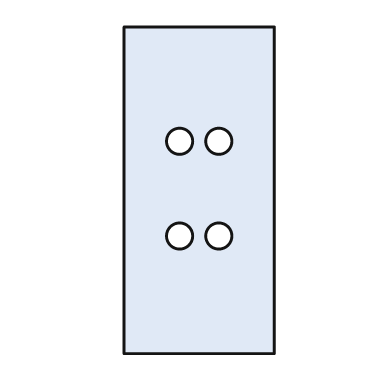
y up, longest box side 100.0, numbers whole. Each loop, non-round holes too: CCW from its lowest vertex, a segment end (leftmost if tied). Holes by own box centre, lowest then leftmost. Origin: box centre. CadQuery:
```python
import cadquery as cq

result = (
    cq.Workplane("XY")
    .moveTo(-23.0, -50.0)
    .lineTo(23.0, -50.0)
    .lineTo(23.0, 50.0)
    .lineTo(-23.0, 50.0)
    .close()
    .moveTo(-6.0, -14.0)
    .circle(4.0)
    .moveTo(6.0, -14.0)
    .circle(4.0)
    .moveTo(-6.0, 15.0)
    .circle(4.0)
    .moveTo(6.0, 15.0)
    .circle(4.0)
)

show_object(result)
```